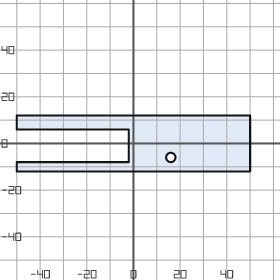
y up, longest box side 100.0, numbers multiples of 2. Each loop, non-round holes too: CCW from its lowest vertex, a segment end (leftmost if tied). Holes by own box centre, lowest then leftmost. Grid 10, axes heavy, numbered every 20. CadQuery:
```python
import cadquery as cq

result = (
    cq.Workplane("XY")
    .moveTo(-50.0, -12.0)
    .lineTo(50.0, -12.0)
    .lineTo(50.0, 12.0)
    .lineTo(-50.0, 12.0)
    .lineTo(-50.0, 6.0)
    .lineTo(-2.0, 6.0)
    .lineTo(-2.0, -8.0)
    .lineTo(-50.0, -8.0)
    .close()
    .moveTo(16.0, -6.0)
    .circle(2.0)
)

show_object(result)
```